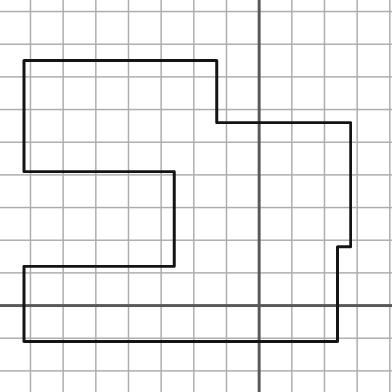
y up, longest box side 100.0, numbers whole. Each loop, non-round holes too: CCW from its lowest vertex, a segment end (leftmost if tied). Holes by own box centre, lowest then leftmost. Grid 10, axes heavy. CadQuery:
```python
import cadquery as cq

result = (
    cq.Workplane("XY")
    .moveTo(-72.0, -11.0)
    .lineTo(24.0, -11.0)
    .lineTo(24.0, 18.0)
    .lineTo(28.0, 18.0)
    .lineTo(28.0, 56.0)
    .lineTo(-13.0, 56.0)
    .lineTo(-13.0, 75.0)
    .lineTo(-72.0, 75.0)
    .lineTo(-72.0, 41.0)
    .lineTo(-26.0, 41.0)
    .lineTo(-26.0, 12.0)
    .lineTo(-72.0, 12.0)
    .close()
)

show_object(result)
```